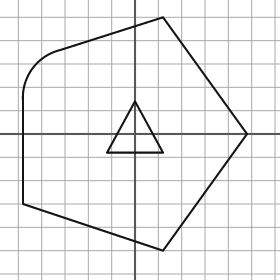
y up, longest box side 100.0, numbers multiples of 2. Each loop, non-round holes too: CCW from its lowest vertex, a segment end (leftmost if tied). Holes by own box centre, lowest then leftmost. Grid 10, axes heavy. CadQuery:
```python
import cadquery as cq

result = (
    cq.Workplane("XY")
    .moveTo(12.0, -50.0)
    .lineTo(48.0, 0.0)
    .lineTo(12.0, 50.0)
    .lineTo(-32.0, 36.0)
    .threePointArc((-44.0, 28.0), (-48.0, 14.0))
    .lineTo(-48.0, -30.0)
    .close()
    .moveTo(-12.0, -8.0)
    .lineTo(12.0, -8.0)
    .lineTo(0.0, 14.0)
    .close()
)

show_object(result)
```